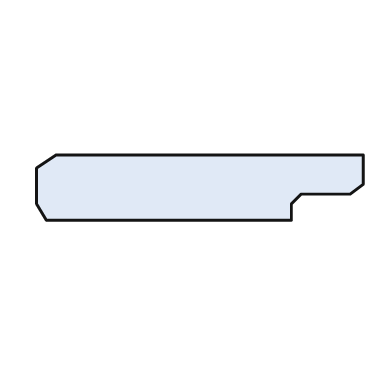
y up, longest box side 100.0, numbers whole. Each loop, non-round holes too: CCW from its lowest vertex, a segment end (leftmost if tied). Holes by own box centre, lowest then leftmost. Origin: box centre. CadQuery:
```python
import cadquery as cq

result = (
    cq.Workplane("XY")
    .moveTo(-47.0, -10.0)
    .lineTo(28.0, -10.0)
    .lineTo(28.0, -5.0)
    .lineTo(31.0, -2.0)
    .lineTo(46.0, -2.0)
    .lineTo(50.0, 1.0)
    .lineTo(50.0, 10.0)
    .lineTo(-44.0, 10.0)
    .lineTo(-50.0, 6.0)
    .lineTo(-50.0, -5.0)
    .close()
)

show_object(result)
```